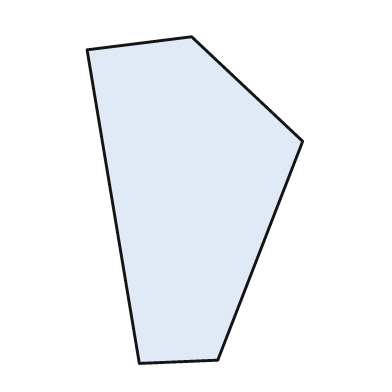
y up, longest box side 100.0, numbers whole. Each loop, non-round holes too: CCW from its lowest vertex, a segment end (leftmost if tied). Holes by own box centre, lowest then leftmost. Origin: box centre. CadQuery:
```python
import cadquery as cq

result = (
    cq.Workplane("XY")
    .moveTo(-17.0, -50.0)
    .lineTo(7.0, -49.0)
    .lineTo(33.0, 18.0)
    .lineTo(-1.0, 50.0)
    .lineTo(-33.0, 46.0)
    .close()
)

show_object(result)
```